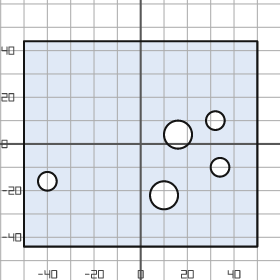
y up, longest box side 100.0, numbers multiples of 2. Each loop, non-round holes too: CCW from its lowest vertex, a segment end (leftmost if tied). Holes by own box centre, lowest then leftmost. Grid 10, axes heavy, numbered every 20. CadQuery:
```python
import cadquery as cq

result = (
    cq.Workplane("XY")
    .moveTo(-50.0, -44.0)
    .lineTo(50.0, -44.0)
    .lineTo(50.0, 44.0)
    .lineTo(-50.0, 44.0)
    .close()
    .moveTo(10.0, -22.0)
    .circle(6.0)
    .moveTo(-40.0, -16.0)
    .circle(4.0)
    .moveTo(34.0, -10.0)
    .circle(4.0)
    .moveTo(16.0, 4.0)
    .circle(6.0)
    .moveTo(32.0, 10.0)
    .circle(4.0)
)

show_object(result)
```